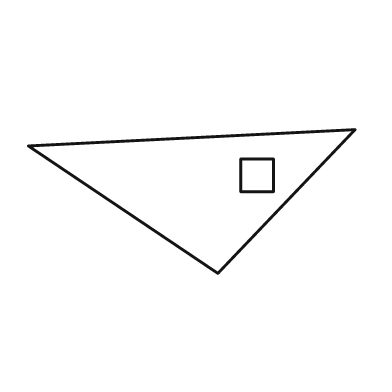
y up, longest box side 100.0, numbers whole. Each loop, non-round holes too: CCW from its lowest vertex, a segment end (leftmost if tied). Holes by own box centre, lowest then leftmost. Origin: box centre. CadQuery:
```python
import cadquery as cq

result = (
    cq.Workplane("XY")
    .moveTo(8.0, -22.0)
    .lineTo(50.0, 22.0)
    .lineTo(-50.0, 17.0)
    .close()
    .moveTo(15.0, 3.0)
    .lineTo(25.0, 3.0)
    .lineTo(25.0, 13.0)
    .lineTo(15.0, 13.0)
    .close()
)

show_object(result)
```